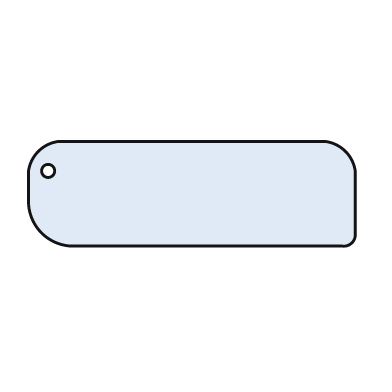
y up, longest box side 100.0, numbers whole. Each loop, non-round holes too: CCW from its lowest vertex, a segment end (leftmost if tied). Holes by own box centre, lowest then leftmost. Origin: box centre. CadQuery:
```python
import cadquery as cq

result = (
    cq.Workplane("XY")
    .moveTo(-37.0, -16.0)
    .lineTo(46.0, -16.0)
    .threePointArc((49.0, -15.0), (50.0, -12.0))
    .lineTo(50.0, 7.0)
    .threePointArc((47.0, 13.0), (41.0, 16.0))
    .lineTo(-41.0, 16.0)
    .threePointArc((-47.0, 13.0), (-50.0, 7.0))
    .lineTo(-50.0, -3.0)
    .threePointArc((-46.0, -12.0), (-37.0, -16.0))
    .close()
    .moveTo(-44.0, 7.0)
    .circle(2.0)
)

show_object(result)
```